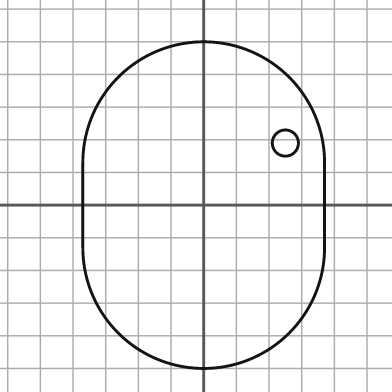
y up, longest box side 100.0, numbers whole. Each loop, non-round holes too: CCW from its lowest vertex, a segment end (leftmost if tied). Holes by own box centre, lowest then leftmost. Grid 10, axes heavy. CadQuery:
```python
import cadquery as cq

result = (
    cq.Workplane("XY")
    .moveTo(-37.0, -13.0)
    .threePointArc((0.0, -50.0), (37.0, -13.0))
    .lineTo(37.0, 13.0)
    .threePointArc((0.0, 50.0), (-37.0, 13.0))
    .close()
    .moveTo(25.0, 19.0)
    .circle(4.0)
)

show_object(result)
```